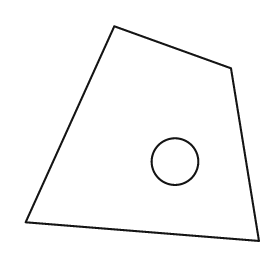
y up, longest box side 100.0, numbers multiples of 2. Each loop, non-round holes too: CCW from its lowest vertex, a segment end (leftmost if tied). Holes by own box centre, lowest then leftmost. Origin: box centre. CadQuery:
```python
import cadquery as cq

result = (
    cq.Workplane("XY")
    .moveTo(50.0, -46.0)
    .lineTo(38.0, 28.0)
    .lineTo(-12.0, 46.0)
    .lineTo(-50.0, -38.0)
    .close()
    .moveTo(14.0, -12.0)
    .circle(10.0)
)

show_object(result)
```